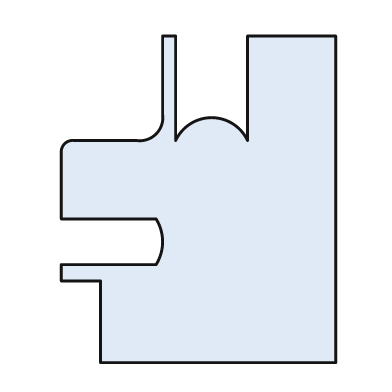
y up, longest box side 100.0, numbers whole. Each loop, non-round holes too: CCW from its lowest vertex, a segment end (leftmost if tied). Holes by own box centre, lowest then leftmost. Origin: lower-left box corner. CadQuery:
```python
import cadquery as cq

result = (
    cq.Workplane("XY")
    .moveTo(12.0, 0.0)
    .lineTo(84.0, 0.0)
    .lineTo(84.0, 100.0)
    .lineTo(57.0, 100.0)
    .lineTo(57.0, 68.0)
    .threePointArc((46.0, 75.0), (35.0, 68.0))
    .lineTo(35.0, 100.0)
    .lineTo(31.0, 100.0)
    .lineTo(31.0, 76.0)
    .threePointArc((29.0, 70.0), (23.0, 68.0))
    .lineTo(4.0, 68.0)
    .threePointArc((1.0, 67.0), (0.0, 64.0))
    .lineTo(0.0, 44.0)
    .lineTo(29.0, 44.0)
    .threePointArc((31.0, 37.0), (29.0, 30.0))
    .lineTo(0.0, 30.0)
    .lineTo(0.0, 25.0)
    .lineTo(12.0, 25.0)
    .close()
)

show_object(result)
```